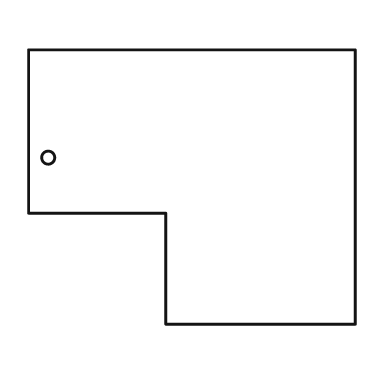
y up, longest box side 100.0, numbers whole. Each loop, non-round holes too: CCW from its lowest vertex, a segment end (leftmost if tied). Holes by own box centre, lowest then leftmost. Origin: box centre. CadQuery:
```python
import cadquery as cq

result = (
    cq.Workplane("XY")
    .moveTo(-8.0, -42.0)
    .lineTo(50.0, -42.0)
    .lineTo(50.0, 42.0)
    .lineTo(-50.0, 42.0)
    .lineTo(-50.0, -8.0)
    .lineTo(-8.0, -8.0)
    .close()
    .moveTo(-44.0, 9.0)
    .circle(2.0)
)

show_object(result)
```